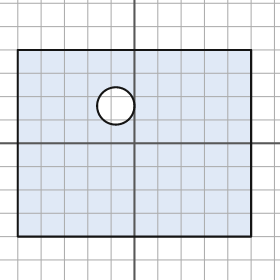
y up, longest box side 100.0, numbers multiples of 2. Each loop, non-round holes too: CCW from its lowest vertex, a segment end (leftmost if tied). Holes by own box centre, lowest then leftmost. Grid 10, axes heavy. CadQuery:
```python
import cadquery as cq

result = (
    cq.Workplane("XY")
    .moveTo(-50.0, -40.0)
    .lineTo(50.0, -40.0)
    .lineTo(50.0, 40.0)
    .lineTo(-50.0, 40.0)
    .close()
    .moveTo(-8.0, 16.0)
    .circle(8.0)
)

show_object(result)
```